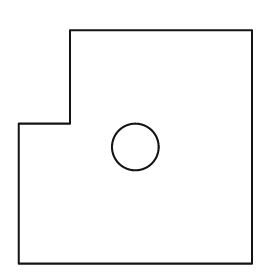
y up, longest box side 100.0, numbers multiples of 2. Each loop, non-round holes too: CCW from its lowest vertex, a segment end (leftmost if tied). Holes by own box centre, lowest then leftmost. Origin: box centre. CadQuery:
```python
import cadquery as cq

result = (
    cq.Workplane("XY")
    .moveTo(-50.0, -50.0)
    .lineTo(50.0, -50.0)
    .lineTo(50.0, 50.0)
    .lineTo(-28.0, 50.0)
    .lineTo(-28.0, 10.0)
    .lineTo(-50.0, 10.0)
    .close()
    .moveTo(0.0, 0.0)
    .circle(10.0)
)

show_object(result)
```